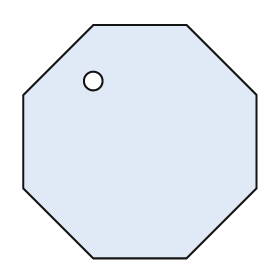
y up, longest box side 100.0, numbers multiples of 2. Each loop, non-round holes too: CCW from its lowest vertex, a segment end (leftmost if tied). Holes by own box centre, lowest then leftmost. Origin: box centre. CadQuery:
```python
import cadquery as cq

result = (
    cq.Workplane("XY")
    .moveTo(-20.0, -50.0)
    .lineTo(20.0, -50.0)
    .lineTo(50.0, -20.0)
    .lineTo(50.0, 20.0)
    .lineTo(20.0, 50.0)
    .lineTo(-20.0, 50.0)
    .lineTo(-50.0, 20.0)
    .lineTo(-50.0, -20.0)
    .close()
    .moveTo(-20.0, 26.0)
    .circle(4.0)
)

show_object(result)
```